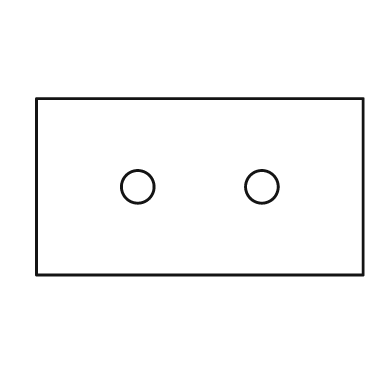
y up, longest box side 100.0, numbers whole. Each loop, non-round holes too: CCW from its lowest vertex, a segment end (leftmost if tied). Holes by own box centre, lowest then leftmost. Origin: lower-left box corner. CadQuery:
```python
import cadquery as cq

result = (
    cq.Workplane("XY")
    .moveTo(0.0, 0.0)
    .lineTo(100.0, 0.0)
    .lineTo(100.0, 54.0)
    .lineTo(0.0, 54.0)
    .close()
    .moveTo(31.0, 27.0)
    .circle(5.0)
    .moveTo(69.0, 27.0)
    .circle(5.0)
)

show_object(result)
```